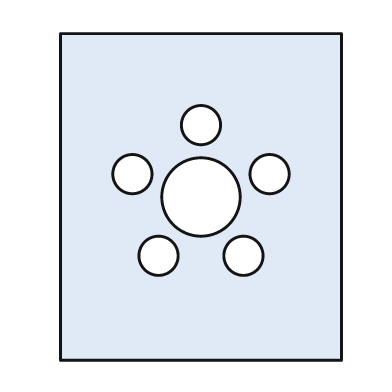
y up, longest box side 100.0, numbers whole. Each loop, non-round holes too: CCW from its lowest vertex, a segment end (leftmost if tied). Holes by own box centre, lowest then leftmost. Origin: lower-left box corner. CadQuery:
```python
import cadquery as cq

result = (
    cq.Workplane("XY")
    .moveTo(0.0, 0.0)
    .lineTo(86.0, 0.0)
    .lineTo(86.0, 100.0)
    .lineTo(0.0, 100.0)
    .close()
    .moveTo(30.0, 32.0)
    .circle(6.0)
    .moveTo(56.0, 32.0)
    .circle(6.0)
    .moveTo(43.0, 50.0)
    .circle(12.0)
    .moveTo(22.0, 57.0)
    .circle(6.0)
    .moveTo(64.0, 57.0)
    .circle(6.0)
    .moveTo(43.0, 72.0)
    .circle(6.0)
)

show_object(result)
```